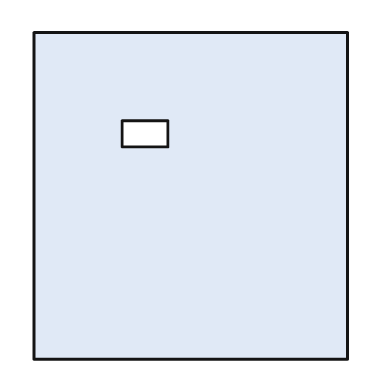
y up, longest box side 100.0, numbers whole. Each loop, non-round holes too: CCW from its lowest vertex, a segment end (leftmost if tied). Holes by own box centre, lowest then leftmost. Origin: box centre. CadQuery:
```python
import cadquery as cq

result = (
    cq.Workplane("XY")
    .moveTo(-48.0, -50.0)
    .lineTo(48.0, -50.0)
    .lineTo(48.0, 50.0)
    .lineTo(-48.0, 50.0)
    .close()
    .moveTo(-21.0, 15.0)
    .lineTo(-7.0, 15.0)
    .lineTo(-7.0, 23.0)
    .lineTo(-21.0, 23.0)
    .close()
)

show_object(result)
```